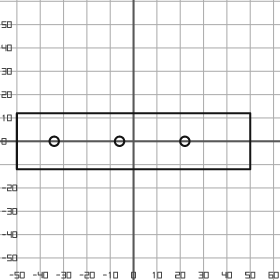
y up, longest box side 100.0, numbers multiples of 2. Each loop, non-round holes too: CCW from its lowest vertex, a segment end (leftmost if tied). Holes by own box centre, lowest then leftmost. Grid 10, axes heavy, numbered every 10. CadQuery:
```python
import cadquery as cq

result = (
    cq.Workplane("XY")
    .moveTo(-50.0, -12.0)
    .lineTo(50.0, -12.0)
    .lineTo(50.0, 12.0)
    .lineTo(-50.0, 12.0)
    .close()
    .moveTo(-34.0, 0.0)
    .circle(2.0)
    .moveTo(-6.0, 0.0)
    .circle(2.0)
    .moveTo(22.0, 0.0)
    .circle(2.0)
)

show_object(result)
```